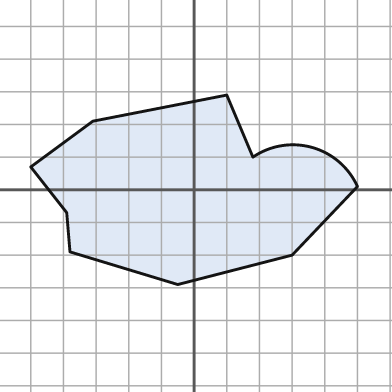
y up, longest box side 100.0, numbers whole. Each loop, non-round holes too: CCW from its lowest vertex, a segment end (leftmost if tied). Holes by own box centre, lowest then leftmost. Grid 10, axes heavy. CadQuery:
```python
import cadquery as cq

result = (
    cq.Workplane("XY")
    .moveTo(-5.0, -29.0)
    .lineTo(30.0, -20.0)
    .lineTo(50.0, 1.0)
    .threePointArc((36.0, 13.0), (18.0, 10.0))
    .lineTo(10.0, 29.0)
    .lineTo(-31.0, 21.0)
    .lineTo(-50.0, 7.0)
    .lineTo(-39.0, -7.0)
    .lineTo(-38.0, -19.0)
    .close()
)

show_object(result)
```